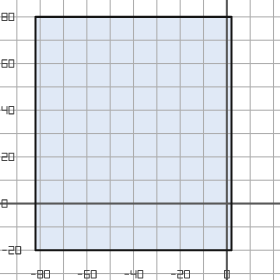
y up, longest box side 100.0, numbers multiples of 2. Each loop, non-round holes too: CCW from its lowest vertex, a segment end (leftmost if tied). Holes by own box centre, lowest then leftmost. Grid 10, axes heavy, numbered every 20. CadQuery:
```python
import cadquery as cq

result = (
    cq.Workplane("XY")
    .moveTo(-82.0, -20.0)
    .lineTo(2.0, -20.0)
    .lineTo(2.0, 80.0)
    .lineTo(-82.0, 80.0)
    .close()
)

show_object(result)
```